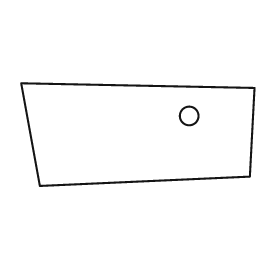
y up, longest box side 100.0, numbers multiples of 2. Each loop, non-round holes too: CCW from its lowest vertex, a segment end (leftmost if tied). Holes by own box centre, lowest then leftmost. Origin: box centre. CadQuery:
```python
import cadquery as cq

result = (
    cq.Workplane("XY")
    .moveTo(-42.0, -22.0)
    .lineTo(48.0, -18.0)
    .lineTo(50.0, 20.0)
    .lineTo(-50.0, 22.0)
    .close()
    .moveTo(22.0, 8.0)
    .circle(4.0)
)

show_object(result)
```